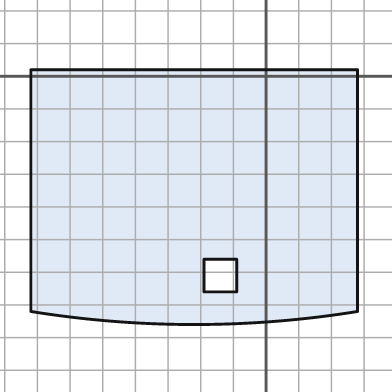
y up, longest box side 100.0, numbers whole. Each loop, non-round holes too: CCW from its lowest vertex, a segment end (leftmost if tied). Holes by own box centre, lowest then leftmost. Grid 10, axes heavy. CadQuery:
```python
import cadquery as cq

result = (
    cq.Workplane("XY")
    .moveTo(-72.0, -72.0)
    .threePointArc((-22.0, -76.0), (28.0, -72.0))
    .lineTo(28.0, 2.0)
    .lineTo(-72.0, 2.0)
    .close()
    .moveTo(-19.0, -66.0)
    .lineTo(-9.0, -66.0)
    .lineTo(-9.0, -56.0)
    .lineTo(-19.0, -56.0)
    .close()
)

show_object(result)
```